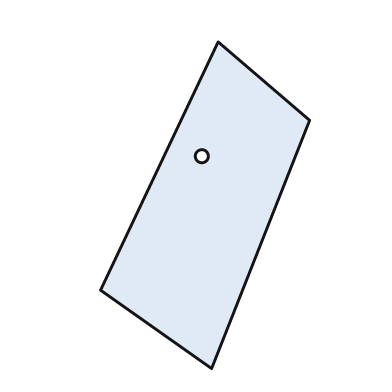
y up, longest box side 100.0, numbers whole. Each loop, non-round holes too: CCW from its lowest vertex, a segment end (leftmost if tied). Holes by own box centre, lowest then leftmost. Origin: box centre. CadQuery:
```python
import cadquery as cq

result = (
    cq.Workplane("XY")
    .moveTo(2.0, -50.0)
    .lineTo(32.0, 26.0)
    .lineTo(4.0, 50.0)
    .lineTo(-32.0, -26.0)
    .close()
    .moveTo(-1.0, 15.0)
    .circle(2.0)
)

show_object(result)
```